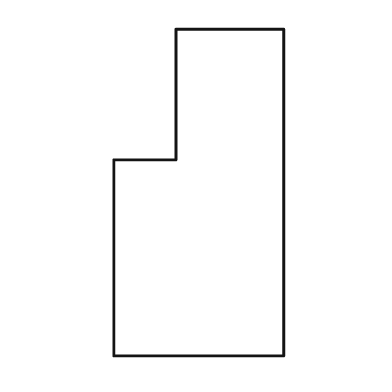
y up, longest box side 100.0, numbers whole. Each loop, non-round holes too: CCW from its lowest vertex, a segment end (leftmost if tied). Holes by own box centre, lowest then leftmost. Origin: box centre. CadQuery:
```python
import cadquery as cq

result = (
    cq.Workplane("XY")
    .moveTo(-26.0, -50.0)
    .lineTo(26.0, -50.0)
    .lineTo(26.0, 50.0)
    .lineTo(-7.0, 50.0)
    .lineTo(-7.0, 10.0)
    .lineTo(-26.0, 10.0)
    .close()
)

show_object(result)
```